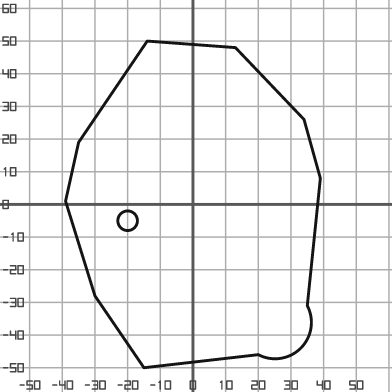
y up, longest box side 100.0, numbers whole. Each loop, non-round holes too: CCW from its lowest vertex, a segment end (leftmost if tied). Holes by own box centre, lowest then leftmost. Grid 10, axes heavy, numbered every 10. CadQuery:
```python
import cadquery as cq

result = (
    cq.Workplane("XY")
    .moveTo(-15.0, -50.0)
    .lineTo(20.0, -46.0)
    .threePointArc((33.0, -44.0), (35.0, -31.0))
    .lineTo(39.0, 8.0)
    .lineTo(34.0, 26.0)
    .lineTo(13.0, 48.0)
    .lineTo(-14.0, 50.0)
    .lineTo(-35.0, 19.0)
    .lineTo(-39.0, 1.0)
    .lineTo(-30.0, -28.0)
    .close()
    .moveTo(-20.0, -5.0)
    .circle(3.0)
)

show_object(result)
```